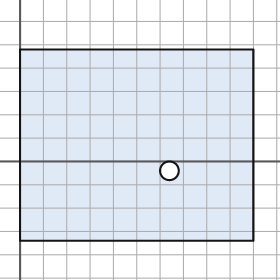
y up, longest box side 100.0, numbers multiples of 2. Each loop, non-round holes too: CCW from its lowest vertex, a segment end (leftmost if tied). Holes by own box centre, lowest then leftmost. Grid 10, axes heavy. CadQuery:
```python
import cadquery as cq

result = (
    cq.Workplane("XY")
    .moveTo(0.0, -34.0)
    .lineTo(100.0, -34.0)
    .lineTo(100.0, 48.0)
    .lineTo(0.0, 48.0)
    .close()
    .moveTo(64.0, -4.0)
    .circle(4.0)
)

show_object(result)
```